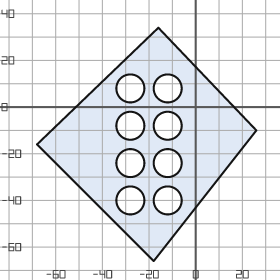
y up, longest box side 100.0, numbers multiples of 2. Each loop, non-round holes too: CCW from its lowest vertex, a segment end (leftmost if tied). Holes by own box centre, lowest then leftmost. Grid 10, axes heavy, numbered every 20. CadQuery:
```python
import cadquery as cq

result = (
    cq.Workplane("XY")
    .moveTo(-18.0, -66.0)
    .lineTo(26.0, -10.0)
    .lineTo(-16.0, 34.0)
    .lineTo(-68.0, -16.0)
    .close()
    .moveTo(-28.0, -40.0)
    .circle(6.0)
    .moveTo(-12.0, -40.0)
    .circle(6.0)
    .moveTo(-28.0, -24.0)
    .circle(6.0)
    .moveTo(-12.0, -24.0)
    .circle(6.0)
    .moveTo(-28.0, -8.0)
    .circle(6.0)
    .moveTo(-12.0, -8.0)
    .circle(6.0)
    .moveTo(-28.0, 8.0)
    .circle(6.0)
    .moveTo(-12.0, 8.0)
    .circle(6.0)
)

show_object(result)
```